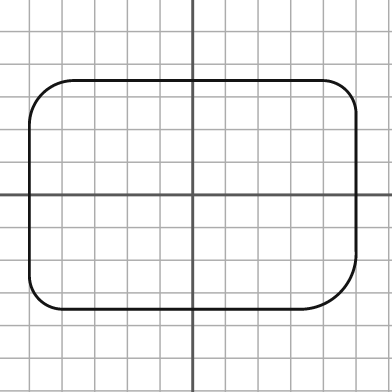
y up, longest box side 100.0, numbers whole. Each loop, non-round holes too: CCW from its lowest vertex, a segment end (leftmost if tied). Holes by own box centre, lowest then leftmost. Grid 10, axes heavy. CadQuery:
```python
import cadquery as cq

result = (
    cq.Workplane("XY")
    .moveTo(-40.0, -35.0)
    .lineTo(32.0, -35.0)
    .threePointArc((45.0, -30.0), (50.0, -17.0))
    .lineTo(50.0, 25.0)
    .threePointArc((47.0, 32.0), (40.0, 35.0))
    .lineTo(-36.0, 35.0)
    .threePointArc((-46.0, 31.0), (-50.0, 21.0))
    .lineTo(-50.0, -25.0)
    .threePointArc((-47.0, -32.0), (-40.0, -35.0))
    .close()
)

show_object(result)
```